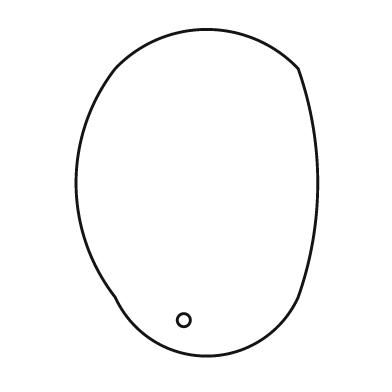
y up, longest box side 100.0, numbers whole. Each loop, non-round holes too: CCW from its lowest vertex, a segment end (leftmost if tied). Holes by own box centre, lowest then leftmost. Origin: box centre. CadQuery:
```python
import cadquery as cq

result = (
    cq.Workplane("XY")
    .moveTo(-25.0, -32.0)
    .threePointArc((3.0, -50.0), (31.0, -32.0))
    .threePointArc((37.0, 3.0), (31.0, 38.0))
    .threePointArc((3.0, 50.0), (-25.0, 38.0))
    .threePointArc((-37.0, 3.0), (-25.0, -32.0))
    .close()
    .moveTo(-4.0, -39.0)
    .circle(2.0)
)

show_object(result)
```